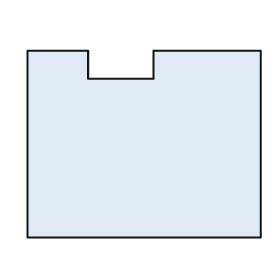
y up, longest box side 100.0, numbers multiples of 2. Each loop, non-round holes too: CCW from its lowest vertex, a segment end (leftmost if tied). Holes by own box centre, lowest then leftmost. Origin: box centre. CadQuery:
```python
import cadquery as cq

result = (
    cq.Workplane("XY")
    .moveTo(-50.0, -40.0)
    .lineTo(50.0, -40.0)
    .lineTo(50.0, 40.0)
    .lineTo(4.0, 40.0)
    .lineTo(4.0, 28.0)
    .lineTo(-24.0, 28.0)
    .lineTo(-24.0, 40.0)
    .lineTo(-50.0, 40.0)
    .close()
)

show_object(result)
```